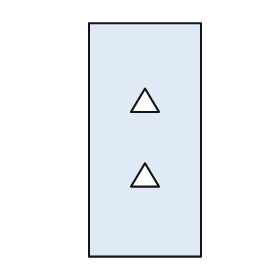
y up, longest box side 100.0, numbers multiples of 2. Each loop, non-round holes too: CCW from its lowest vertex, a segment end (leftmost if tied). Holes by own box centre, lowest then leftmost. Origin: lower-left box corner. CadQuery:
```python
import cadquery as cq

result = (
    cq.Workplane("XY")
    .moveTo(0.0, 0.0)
    .lineTo(48.0, 0.0)
    .lineTo(48.0, 100.0)
    .lineTo(0.0, 100.0)
    .close()
    .moveTo(18.0, 30.0)
    .lineTo(30.0, 30.0)
    .lineTo(24.0, 40.0)
    .close()
    .moveTo(18.0, 62.0)
    .lineTo(30.0, 62.0)
    .lineTo(24.0, 72.0)
    .close()
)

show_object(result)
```